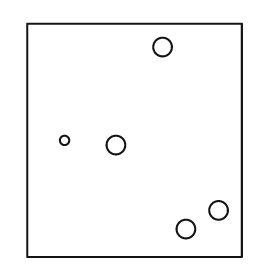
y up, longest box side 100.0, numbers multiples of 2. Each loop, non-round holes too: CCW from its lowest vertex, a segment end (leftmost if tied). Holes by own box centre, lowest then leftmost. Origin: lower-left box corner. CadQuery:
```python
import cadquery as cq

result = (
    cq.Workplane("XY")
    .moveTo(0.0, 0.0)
    .lineTo(92.0, 0.0)
    .lineTo(92.0, 100.0)
    .lineTo(0.0, 100.0)
    .close()
    .moveTo(68.0, 12.0)
    .circle(4.0)
    .moveTo(82.0, 20.0)
    .circle(4.0)
    .moveTo(38.0, 48.0)
    .circle(4.0)
    .moveTo(16.0, 50.0)
    .circle(2.0)
    .moveTo(58.0, 90.0)
    .circle(4.0)
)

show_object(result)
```